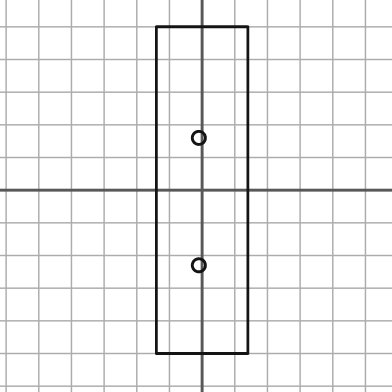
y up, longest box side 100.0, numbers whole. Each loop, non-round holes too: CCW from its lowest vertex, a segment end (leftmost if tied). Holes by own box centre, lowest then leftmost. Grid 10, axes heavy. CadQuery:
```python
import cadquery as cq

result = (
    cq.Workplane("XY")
    .moveTo(-14.0, -50.0)
    .lineTo(14.0, -50.0)
    .lineTo(14.0, 50.0)
    .lineTo(-14.0, 50.0)
    .close()
    .moveTo(-1.0, -23.0)
    .circle(2.0)
    .moveTo(-1.0, 16.0)
    .circle(2.0)
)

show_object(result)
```